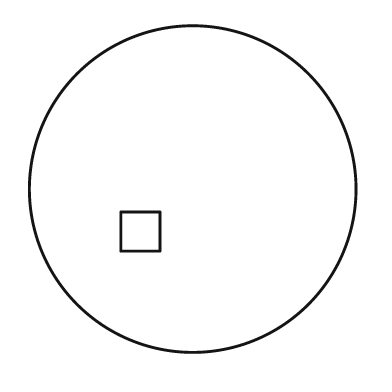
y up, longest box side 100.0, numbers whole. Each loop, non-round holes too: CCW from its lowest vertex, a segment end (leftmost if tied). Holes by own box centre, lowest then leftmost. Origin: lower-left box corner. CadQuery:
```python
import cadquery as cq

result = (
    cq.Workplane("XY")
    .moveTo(50.0, 50.0)
    .circle(50.0)
    .moveTo(28.0, 31.0)
    .lineTo(40.0, 31.0)
    .lineTo(40.0, 43.0)
    .lineTo(28.0, 43.0)
    .close()
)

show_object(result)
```